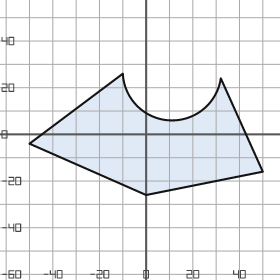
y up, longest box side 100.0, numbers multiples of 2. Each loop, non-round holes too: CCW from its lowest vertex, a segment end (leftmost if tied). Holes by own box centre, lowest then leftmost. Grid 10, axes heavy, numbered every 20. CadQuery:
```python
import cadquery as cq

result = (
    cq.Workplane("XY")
    .moveTo(0.0, -26.0)
    .lineTo(50.0, -16.0)
    .lineTo(32.0, 24.0)
    .threePointArc((10.0, 6.0), (-10.0, 26.0))
    .lineTo(-50.0, -4.0)
    .close()
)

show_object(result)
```